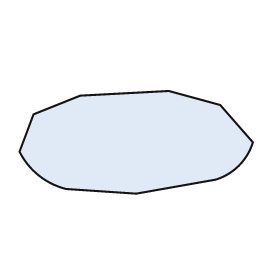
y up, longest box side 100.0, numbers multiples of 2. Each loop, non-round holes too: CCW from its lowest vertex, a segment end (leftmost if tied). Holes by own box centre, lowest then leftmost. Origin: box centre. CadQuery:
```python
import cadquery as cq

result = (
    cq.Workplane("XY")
    .moveTo(0.0, -22.0)
    .lineTo(34.0, -16.0)
    .threePointArc((44.0, -10.0), (50.0, 0.0))
    .lineTo(36.0, 16.0)
    .lineTo(14.0, 22.0)
    .lineTo(-24.0, 20.0)
    .lineTo(-44.0, 12.0)
    .lineTo(-50.0, -4.0)
    .threePointArc((-42.0, -14.0), (-30.0, -20.0))
    .close()
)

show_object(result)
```